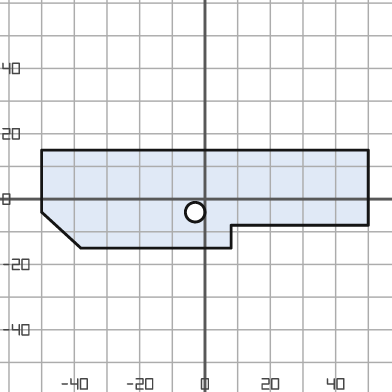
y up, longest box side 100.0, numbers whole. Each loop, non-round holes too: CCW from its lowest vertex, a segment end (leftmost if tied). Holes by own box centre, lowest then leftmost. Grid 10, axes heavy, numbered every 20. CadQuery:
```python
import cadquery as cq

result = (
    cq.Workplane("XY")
    .moveTo(-38.0, -15.0)
    .lineTo(8.0, -15.0)
    .lineTo(8.0, -8.0)
    .lineTo(50.0, -8.0)
    .lineTo(50.0, 15.0)
    .lineTo(-50.0, 15.0)
    .lineTo(-50.0, -4.0)
    .close()
    .moveTo(-3.0, -4.0)
    .circle(3.0)
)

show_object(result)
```